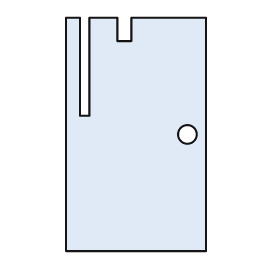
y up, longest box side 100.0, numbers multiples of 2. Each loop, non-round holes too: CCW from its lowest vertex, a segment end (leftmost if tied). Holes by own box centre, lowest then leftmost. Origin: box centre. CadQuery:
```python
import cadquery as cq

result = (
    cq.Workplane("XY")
    .moveTo(-30.0, -50.0)
    .lineTo(30.0, -50.0)
    .lineTo(30.0, 50.0)
    .lineTo(-2.0, 50.0)
    .lineTo(-2.0, 40.0)
    .lineTo(-8.0, 40.0)
    .lineTo(-8.0, 50.0)
    .lineTo(-20.0, 50.0)
    .lineTo(-20.0, 8.0)
    .lineTo(-24.0, 8.0)
    .lineTo(-24.0, 50.0)
    .lineTo(-30.0, 50.0)
    .close()
    .moveTo(22.0, 0.0)
    .circle(4.0)
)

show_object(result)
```